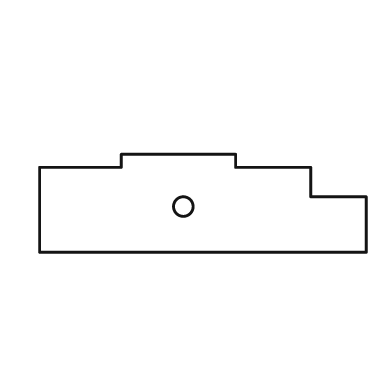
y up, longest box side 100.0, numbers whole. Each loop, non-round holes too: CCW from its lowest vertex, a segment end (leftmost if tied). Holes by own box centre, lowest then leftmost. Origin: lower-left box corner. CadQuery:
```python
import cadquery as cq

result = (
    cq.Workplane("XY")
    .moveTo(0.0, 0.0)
    .lineTo(100.0, 0.0)
    .lineTo(100.0, 17.0)
    .lineTo(83.0, 17.0)
    .lineTo(83.0, 26.0)
    .lineTo(60.0, 26.0)
    .lineTo(60.0, 30.0)
    .lineTo(25.0, 30.0)
    .lineTo(25.0, 26.0)
    .lineTo(0.0, 26.0)
    .close()
    .moveTo(44.0, 14.0)
    .circle(3.0)
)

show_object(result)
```